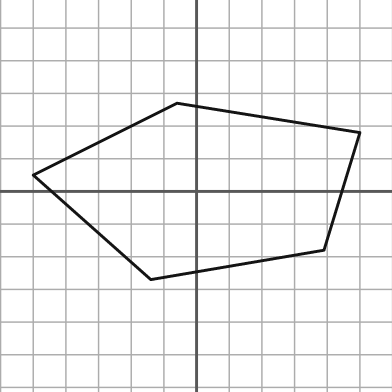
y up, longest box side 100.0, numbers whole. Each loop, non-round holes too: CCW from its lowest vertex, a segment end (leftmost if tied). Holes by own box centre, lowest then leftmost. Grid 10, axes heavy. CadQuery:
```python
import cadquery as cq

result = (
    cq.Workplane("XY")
    .moveTo(-14.0, -27.0)
    .lineTo(39.0, -18.0)
    .lineTo(50.0, 18.0)
    .lineTo(-6.0, 27.0)
    .lineTo(-50.0, 5.0)
    .close()
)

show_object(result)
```